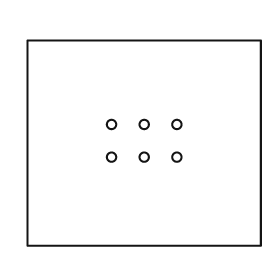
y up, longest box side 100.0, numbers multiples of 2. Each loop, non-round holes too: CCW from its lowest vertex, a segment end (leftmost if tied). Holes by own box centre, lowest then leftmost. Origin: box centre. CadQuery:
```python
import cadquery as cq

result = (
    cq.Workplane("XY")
    .moveTo(-50.0, -44.0)
    .lineTo(50.0, -44.0)
    .lineTo(50.0, 44.0)
    .lineTo(-50.0, 44.0)
    .close()
    .moveTo(-14.0, -6.0)
    .circle(2.0)
    .moveTo(0.0, -6.0)
    .circle(2.0)
    .moveTo(14.0, -6.0)
    .circle(2.0)
    .moveTo(-14.0, 8.0)
    .circle(2.0)
    .moveTo(0.0, 8.0)
    .circle(2.0)
    .moveTo(14.0, 8.0)
    .circle(2.0)
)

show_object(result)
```